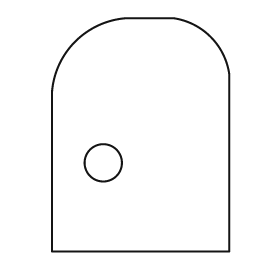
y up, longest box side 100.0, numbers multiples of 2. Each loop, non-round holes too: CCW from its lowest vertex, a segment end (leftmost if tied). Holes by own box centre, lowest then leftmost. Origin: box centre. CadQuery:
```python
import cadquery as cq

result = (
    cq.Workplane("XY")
    .moveTo(-38.0, -50.0)
    .lineTo(38.0, -50.0)
    .lineTo(38.0, 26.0)
    .threePointArc((30.0, 42.0), (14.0, 50.0))
    .lineTo(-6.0, 50.0)
    .threePointArc((-28.0, 40.0), (-38.0, 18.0))
    .close()
    .moveTo(-16.0, -12.0)
    .circle(8.0)
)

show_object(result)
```